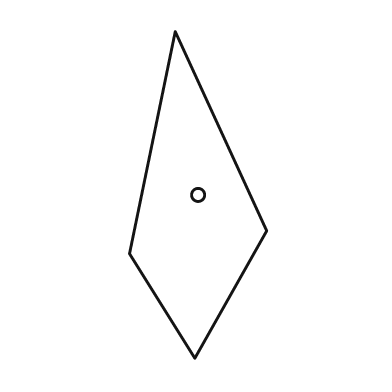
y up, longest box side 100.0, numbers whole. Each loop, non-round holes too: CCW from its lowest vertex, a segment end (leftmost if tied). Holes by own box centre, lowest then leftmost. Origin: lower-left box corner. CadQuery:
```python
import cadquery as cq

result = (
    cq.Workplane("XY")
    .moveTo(20.0, 0.0)
    .lineTo(42.0, 39.0)
    .lineTo(14.0, 100.0)
    .lineTo(0.0, 32.0)
    .close()
    .moveTo(21.0, 50.0)
    .circle(2.0)
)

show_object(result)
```